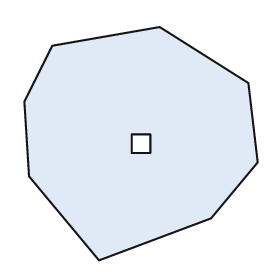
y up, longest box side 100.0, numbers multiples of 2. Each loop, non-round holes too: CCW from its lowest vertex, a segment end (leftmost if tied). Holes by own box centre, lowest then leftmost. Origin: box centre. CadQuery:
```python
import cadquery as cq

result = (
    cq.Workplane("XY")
    .moveTo(-18.0, -50.0)
    .lineTo(30.0, -32.0)
    .lineTo(50.0, -8.0)
    .lineTo(46.0, 26.0)
    .lineTo(8.0, 50.0)
    .lineTo(-38.0, 42.0)
    .lineTo(-50.0, 18.0)
    .lineTo(-48.0, -14.0)
    .close()
    .moveTo(-4.0, -4.0)
    .lineTo(4.0, -4.0)
    .lineTo(4.0, 4.0)
    .lineTo(-4.0, 4.0)
    .close()
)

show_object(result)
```